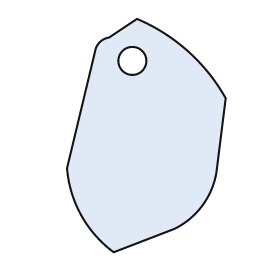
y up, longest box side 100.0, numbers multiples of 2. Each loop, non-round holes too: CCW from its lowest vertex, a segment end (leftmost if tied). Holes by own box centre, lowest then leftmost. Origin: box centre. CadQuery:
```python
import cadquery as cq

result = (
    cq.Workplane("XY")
    .moveTo(-14.0, -50.0)
    .lineTo(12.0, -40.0)
    .threePointArc((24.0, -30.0), (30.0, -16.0))
    .lineTo(34.0, 16.0)
    .threePointArc((18.0, 36.0), (-4.0, 50.0))
    .lineTo(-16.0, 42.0)
    .threePointArc((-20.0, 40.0), (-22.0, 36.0))
    .lineTo(-34.0, -14.0)
    .threePointArc((-28.0, -34.0), (-14.0, -50.0))
    .close()
    .moveTo(-6.0, 32.0)
    .circle(6.0)
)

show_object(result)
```